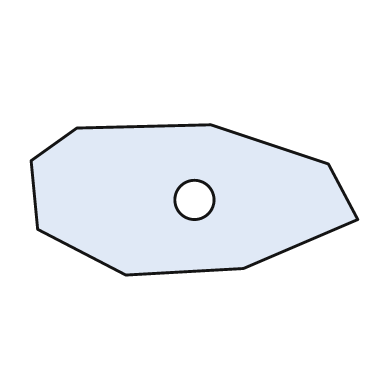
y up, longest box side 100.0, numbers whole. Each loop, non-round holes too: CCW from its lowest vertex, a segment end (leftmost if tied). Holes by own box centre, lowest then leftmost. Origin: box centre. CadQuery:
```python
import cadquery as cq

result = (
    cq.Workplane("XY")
    .moveTo(-21.0, -23.0)
    .lineTo(15.0, -21.0)
    .lineTo(50.0, -6.0)
    .lineTo(41.0, 11.0)
    .lineTo(5.0, 23.0)
    .lineTo(-36.0, 22.0)
    .lineTo(-50.0, 12.0)
    .lineTo(-48.0, -9.0)
    .close()
    .moveTo(0.0, 0.0)
    .circle(6.0)
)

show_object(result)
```